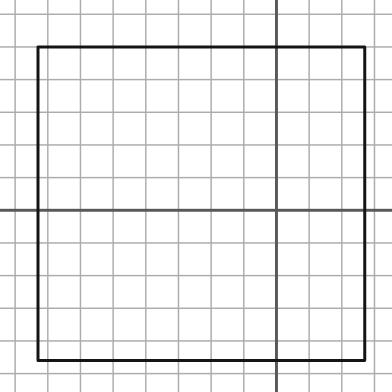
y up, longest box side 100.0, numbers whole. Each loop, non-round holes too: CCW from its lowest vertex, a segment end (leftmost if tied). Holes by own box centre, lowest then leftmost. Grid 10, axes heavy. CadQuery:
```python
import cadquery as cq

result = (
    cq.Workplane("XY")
    .moveTo(-73.0, -46.0)
    .lineTo(27.0, -46.0)
    .lineTo(27.0, 50.0)
    .lineTo(-73.0, 50.0)
    .close()
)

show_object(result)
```